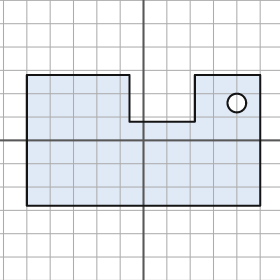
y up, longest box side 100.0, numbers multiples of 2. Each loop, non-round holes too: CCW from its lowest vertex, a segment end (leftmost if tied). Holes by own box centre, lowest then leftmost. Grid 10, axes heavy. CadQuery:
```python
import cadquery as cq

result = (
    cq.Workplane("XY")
    .moveTo(-50.0, -28.0)
    .lineTo(50.0, -28.0)
    .lineTo(50.0, 28.0)
    .lineTo(22.0, 28.0)
    .lineTo(22.0, 8.0)
    .lineTo(-6.0, 8.0)
    .lineTo(-6.0, 28.0)
    .lineTo(-50.0, 28.0)
    .close()
    .moveTo(40.0, 16.0)
    .circle(4.0)
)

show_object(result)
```